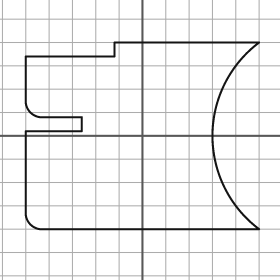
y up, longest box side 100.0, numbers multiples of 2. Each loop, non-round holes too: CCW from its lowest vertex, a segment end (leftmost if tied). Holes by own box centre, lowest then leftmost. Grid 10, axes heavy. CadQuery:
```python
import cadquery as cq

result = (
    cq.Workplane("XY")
    .moveTo(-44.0, -40.0)
    .lineTo(50.0, -40.0)
    .threePointArc((30.0, 0.0), (50.0, 40.0))
    .lineTo(-12.0, 40.0)
    .lineTo(-12.0, 34.0)
    .lineTo(-50.0, 34.0)
    .lineTo(-50.0, 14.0)
    .threePointArc((-48.0, 10.0), (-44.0, 8.0))
    .lineTo(-26.0, 8.0)
    .lineTo(-26.0, 2.0)
    .lineTo(-50.0, 2.0)
    .lineTo(-50.0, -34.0)
    .threePointArc((-48.0, -38.0), (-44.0, -40.0))
    .close()
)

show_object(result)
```